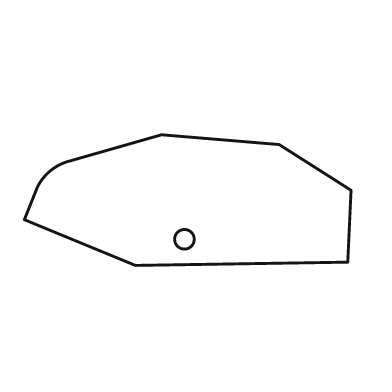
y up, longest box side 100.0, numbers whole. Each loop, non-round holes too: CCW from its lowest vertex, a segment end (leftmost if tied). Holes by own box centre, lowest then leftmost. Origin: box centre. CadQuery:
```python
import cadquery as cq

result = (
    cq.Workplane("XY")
    .moveTo(-16.0, -20.0)
    .lineTo(49.0, -19.0)
    .lineTo(50.0, 3.0)
    .lineTo(28.0, 17.0)
    .lineTo(-8.0, 20.0)
    .lineTo(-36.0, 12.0)
    .threePointArc((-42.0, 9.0), (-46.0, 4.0))
    .lineTo(-50.0, -6.0)
    .close()
    .moveTo(-1.0, -12.0)
    .circle(3.0)
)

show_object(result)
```